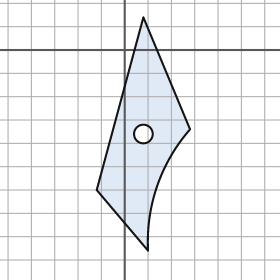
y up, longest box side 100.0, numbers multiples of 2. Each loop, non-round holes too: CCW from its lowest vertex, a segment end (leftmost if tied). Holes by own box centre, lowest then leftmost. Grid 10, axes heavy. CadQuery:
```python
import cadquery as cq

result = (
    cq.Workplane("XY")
    .moveTo(10.0, -86.0)
    .threePointArc((14.0, -58.0), (28.0, -34.0))
    .lineTo(8.0, 14.0)
    .lineTo(-12.0, -60.0)
    .close()
    .moveTo(8.0, -36.0)
    .circle(4.0)
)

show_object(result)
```